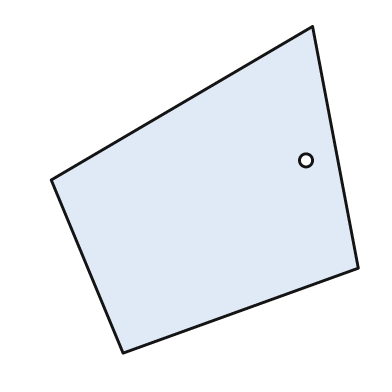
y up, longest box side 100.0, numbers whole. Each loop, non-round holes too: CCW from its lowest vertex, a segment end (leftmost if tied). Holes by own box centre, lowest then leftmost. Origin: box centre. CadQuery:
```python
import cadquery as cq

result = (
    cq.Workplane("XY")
    .moveTo(-25.0, -50.0)
    .lineTo(47.0, -24.0)
    .lineTo(33.0, 50.0)
    .lineTo(-47.0, 3.0)
    .close()
    .moveTo(31.0, 9.0)
    .circle(2.0)
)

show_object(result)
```